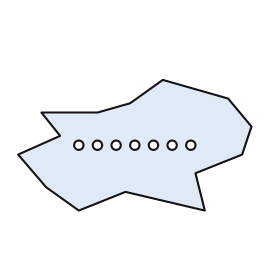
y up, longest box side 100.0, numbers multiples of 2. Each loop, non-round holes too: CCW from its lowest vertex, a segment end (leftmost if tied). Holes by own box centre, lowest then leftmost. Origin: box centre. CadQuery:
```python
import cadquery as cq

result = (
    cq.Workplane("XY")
    .moveTo(-24.0, -28.0)
    .lineTo(-4.0, -20.0)
    .lineTo(30.0, -28.0)
    .lineTo(26.0, -12.0)
    .lineTo(46.0, -4.0)
    .lineTo(50.0, 8.0)
    .lineTo(40.0, 20.0)
    .lineTo(12.0, 28.0)
    .lineTo(-2.0, 18.0)
    .lineTo(-16.0, 14.0)
    .lineTo(-40.0, 14.0)
    .lineTo(-32.0, 4.0)
    .lineTo(-50.0, -4.0)
    .lineTo(-38.0, -18.0)
    .close()
    .moveTo(-24.0, 0.0)
    .circle(2.0)
    .moveTo(-16.0, 0.0)
    .circle(2.0)
    .moveTo(-8.0, 0.0)
    .circle(2.0)
    .moveTo(0.0, 0.0)
    .circle(2.0)
    .moveTo(8.0, 0.0)
    .circle(2.0)
    .moveTo(16.0, 0.0)
    .circle(2.0)
    .moveTo(24.0, 0.0)
    .circle(2.0)
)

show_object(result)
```